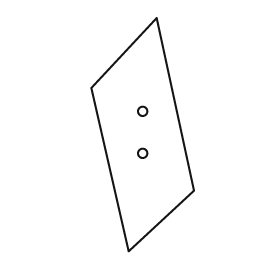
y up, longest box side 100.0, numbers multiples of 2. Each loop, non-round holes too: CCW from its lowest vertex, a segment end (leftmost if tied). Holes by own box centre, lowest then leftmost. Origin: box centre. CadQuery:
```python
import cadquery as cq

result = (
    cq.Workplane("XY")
    .moveTo(-6.0, -50.0)
    .lineTo(22.0, -24.0)
    .lineTo(6.0, 50.0)
    .lineTo(-22.0, 20.0)
    .close()
    .moveTo(0.0, -8.0)
    .circle(2.0)
    .moveTo(0.0, 10.0)
    .circle(2.0)
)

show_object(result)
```